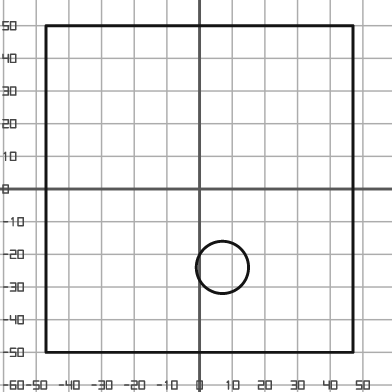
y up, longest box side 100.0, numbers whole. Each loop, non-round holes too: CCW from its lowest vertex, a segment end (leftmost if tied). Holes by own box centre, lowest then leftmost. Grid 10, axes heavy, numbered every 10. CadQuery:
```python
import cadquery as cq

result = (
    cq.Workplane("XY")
    .moveTo(-47.0, -50.0)
    .lineTo(47.0, -50.0)
    .lineTo(47.0, 50.0)
    .lineTo(-47.0, 50.0)
    .close()
    .moveTo(7.0, -24.0)
    .circle(8.0)
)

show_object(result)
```